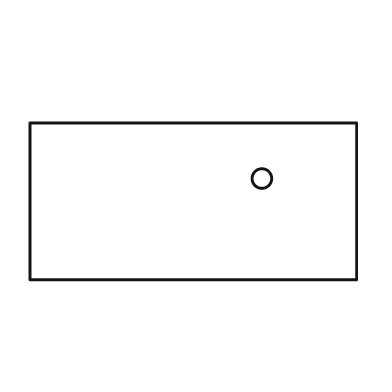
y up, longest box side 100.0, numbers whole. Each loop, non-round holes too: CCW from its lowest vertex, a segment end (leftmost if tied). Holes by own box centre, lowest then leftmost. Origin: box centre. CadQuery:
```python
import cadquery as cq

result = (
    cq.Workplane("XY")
    .moveTo(-50.0, -24.0)
    .lineTo(50.0, -24.0)
    .lineTo(50.0, 24.0)
    .lineTo(-50.0, 24.0)
    .close()
    .moveTo(21.0, 7.0)
    .circle(3.0)
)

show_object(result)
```